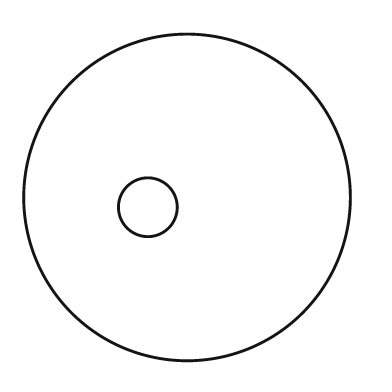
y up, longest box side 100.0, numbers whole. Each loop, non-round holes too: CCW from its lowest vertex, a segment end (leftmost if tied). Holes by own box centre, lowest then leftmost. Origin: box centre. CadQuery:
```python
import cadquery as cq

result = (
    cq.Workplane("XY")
    .moveTo(0.0, 0.0)
    .circle(50.0)
    .moveTo(-12.0, -3.0)
    .circle(9.0)
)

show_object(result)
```